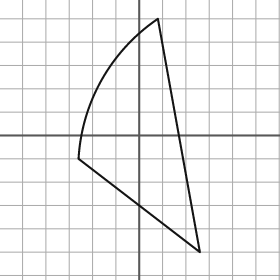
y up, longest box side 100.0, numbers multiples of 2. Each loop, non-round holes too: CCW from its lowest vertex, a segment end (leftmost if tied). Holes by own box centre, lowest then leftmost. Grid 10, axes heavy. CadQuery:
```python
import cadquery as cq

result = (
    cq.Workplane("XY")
    .moveTo(26.0, -50.0)
    .lineTo(8.0, 50.0)
    .threePointArc((-16.0, 24.0), (-26.0, -10.0))
    .close()
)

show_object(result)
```